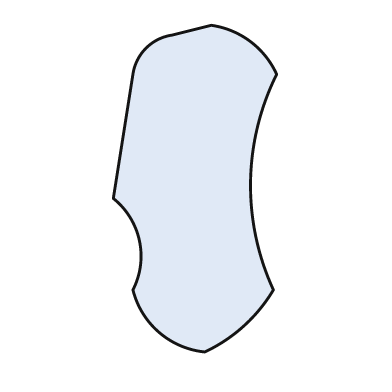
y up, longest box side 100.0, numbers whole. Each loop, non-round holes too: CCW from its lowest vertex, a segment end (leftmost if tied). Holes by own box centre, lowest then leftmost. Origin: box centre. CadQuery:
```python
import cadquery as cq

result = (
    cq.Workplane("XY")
    .moveTo(3.0, -50.0)
    .threePointArc((15.0, -42.0), (24.0, -31.0))
    .threePointArc((17.0, 2.0), (25.0, 35.0))
    .threePointArc((17.0, 45.0), (5.0, 50.0))
    .lineTo(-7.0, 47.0)
    .threePointArc((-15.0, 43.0), (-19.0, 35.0))
    .lineTo(-25.0, -3.0)
    .threePointArc((-17.0, -16.0), (-19.0, -31.0))
    .threePointArc((-11.0, -44.0), (3.0, -50.0))
    .close()
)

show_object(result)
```